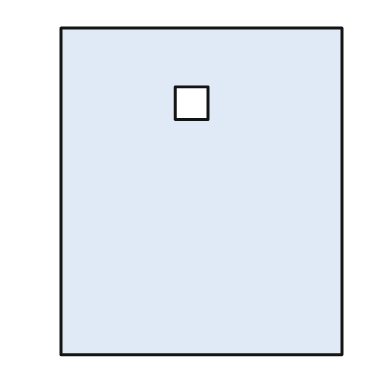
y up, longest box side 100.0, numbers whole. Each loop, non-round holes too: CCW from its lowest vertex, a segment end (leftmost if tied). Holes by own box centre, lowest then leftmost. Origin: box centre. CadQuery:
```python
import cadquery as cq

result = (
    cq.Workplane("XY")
    .moveTo(-43.0, -50.0)
    .lineTo(43.0, -50.0)
    .lineTo(43.0, 50.0)
    .lineTo(-43.0, 50.0)
    .close()
    .moveTo(-8.0, 22.0)
    .lineTo(2.0, 22.0)
    .lineTo(2.0, 32.0)
    .lineTo(-8.0, 32.0)
    .close()
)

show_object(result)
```